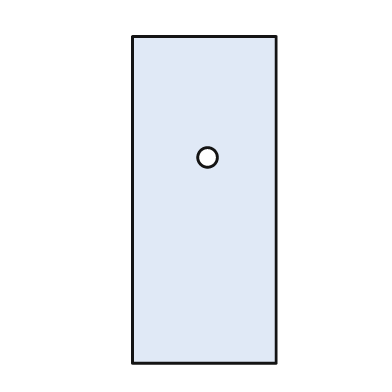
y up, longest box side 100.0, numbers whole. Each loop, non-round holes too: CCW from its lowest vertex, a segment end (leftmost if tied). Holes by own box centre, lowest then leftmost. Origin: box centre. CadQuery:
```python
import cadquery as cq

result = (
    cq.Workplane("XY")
    .moveTo(-22.0, -50.0)
    .lineTo(22.0, -50.0)
    .lineTo(22.0, 50.0)
    .lineTo(-22.0, 50.0)
    .close()
    .moveTo(1.0, 13.0)
    .circle(3.0)
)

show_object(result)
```